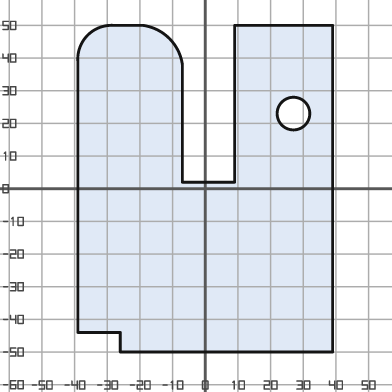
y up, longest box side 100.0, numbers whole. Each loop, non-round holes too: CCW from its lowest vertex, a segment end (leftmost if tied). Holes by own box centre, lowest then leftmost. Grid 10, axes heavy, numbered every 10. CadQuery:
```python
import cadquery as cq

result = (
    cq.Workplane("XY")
    .moveTo(-26.0, -50.0)
    .lineTo(39.0, -50.0)
    .lineTo(39.0, 50.0)
    .lineTo(9.0, 50.0)
    .lineTo(9.0, 2.0)
    .lineTo(-7.0, 2.0)
    .lineTo(-7.0, 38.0)
    .threePointArc((-11.0, 46.0), (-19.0, 50.0))
    .lineTo(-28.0, 50.0)
    .threePointArc((-36.0, 47.0), (-39.0, 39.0))
    .lineTo(-39.0, -44.0)
    .lineTo(-26.0, -44.0)
    .close()
    .moveTo(27.0, 23.0)
    .circle(5.0)
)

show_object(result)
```